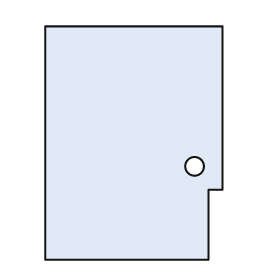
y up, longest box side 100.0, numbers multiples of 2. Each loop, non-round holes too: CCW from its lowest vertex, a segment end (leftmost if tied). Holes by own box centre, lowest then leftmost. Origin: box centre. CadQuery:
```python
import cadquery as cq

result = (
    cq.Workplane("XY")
    .moveTo(-38.0, -50.0)
    .lineTo(32.0, -50.0)
    .lineTo(32.0, -20.0)
    .lineTo(38.0, -20.0)
    .lineTo(38.0, 50.0)
    .lineTo(-38.0, 50.0)
    .close()
    .moveTo(26.0, -10.0)
    .circle(4.0)
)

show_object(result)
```